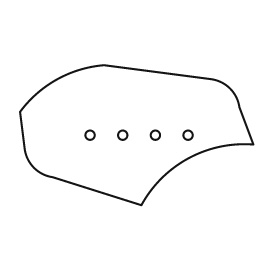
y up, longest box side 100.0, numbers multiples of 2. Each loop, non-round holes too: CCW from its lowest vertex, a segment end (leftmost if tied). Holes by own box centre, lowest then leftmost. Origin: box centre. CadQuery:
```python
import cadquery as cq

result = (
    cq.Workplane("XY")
    .moveTo(2.0, -30.0)
    .threePointArc((22.0, -10.0), (50.0, -4.0))
    .lineTo(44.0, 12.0)
    .threePointArc((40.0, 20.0), (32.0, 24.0))
    .lineTo(-14.0, 30.0)
    .threePointArc((-34.0, 24.0), (-50.0, 10.0))
    .lineTo(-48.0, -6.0)
    .threePointArc((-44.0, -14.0), (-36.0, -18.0))
    .close()
    .moveTo(-20.0, 0.0)
    .circle(2.0)
    .moveTo(-6.0, 0.0)
    .circle(2.0)
    .moveTo(8.0, 0.0)
    .circle(2.0)
    .moveTo(22.0, 0.0)
    .circle(2.0)
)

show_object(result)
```